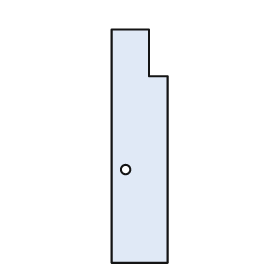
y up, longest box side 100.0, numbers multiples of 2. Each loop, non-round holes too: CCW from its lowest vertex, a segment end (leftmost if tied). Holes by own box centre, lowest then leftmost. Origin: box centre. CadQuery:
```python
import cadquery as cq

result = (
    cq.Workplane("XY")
    .moveTo(-12.0, -50.0)
    .lineTo(12.0, -50.0)
    .lineTo(12.0, 30.0)
    .lineTo(4.0, 30.0)
    .lineTo(4.0, 50.0)
    .lineTo(-12.0, 50.0)
    .close()
    .moveTo(-6.0, -10.0)
    .circle(2.0)
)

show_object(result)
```